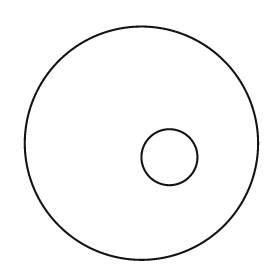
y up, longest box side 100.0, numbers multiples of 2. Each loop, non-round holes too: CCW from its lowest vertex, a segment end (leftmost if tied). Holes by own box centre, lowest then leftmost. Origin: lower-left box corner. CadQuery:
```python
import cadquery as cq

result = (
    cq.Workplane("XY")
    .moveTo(50.0, 50.0)
    .circle(50.0)
    .moveTo(62.0, 44.0)
    .circle(12.0)
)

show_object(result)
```